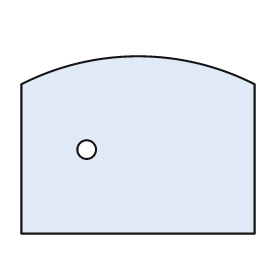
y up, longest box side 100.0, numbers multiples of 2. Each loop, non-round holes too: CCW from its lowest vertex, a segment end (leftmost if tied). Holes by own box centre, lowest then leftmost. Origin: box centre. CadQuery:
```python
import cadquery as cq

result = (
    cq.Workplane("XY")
    .moveTo(-50.0, -38.0)
    .lineTo(50.0, -38.0)
    .lineTo(50.0, 26.0)
    .threePointArc((0.0, 38.0), (-50.0, 26.0))
    .close()
    .moveTo(-22.0, -2.0)
    .circle(4.0)
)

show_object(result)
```